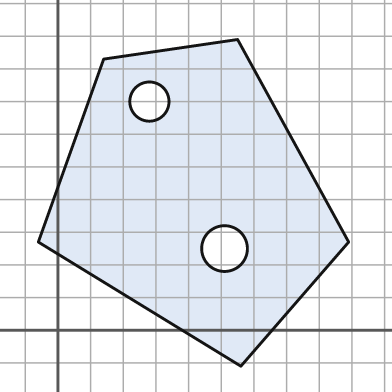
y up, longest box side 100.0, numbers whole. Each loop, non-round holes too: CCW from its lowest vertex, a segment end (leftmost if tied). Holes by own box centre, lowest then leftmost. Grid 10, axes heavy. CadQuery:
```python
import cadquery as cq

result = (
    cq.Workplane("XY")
    .moveTo(56.0, -11.0)
    .lineTo(89.0, 27.0)
    .lineTo(55.0, 89.0)
    .lineTo(14.0, 83.0)
    .lineTo(-6.0, 27.0)
    .close()
    .moveTo(51.0, 25.0)
    .circle(7.0)
    .moveTo(28.0, 70.0)
    .circle(6.0)
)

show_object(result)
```